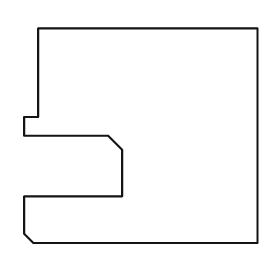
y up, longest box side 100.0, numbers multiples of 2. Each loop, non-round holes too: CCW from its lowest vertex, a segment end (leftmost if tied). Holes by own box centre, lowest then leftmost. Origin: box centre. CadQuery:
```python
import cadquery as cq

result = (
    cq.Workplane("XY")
    .moveTo(-46.0, -46.0)
    .lineTo(50.0, -46.0)
    .lineTo(50.0, 46.0)
    .lineTo(-44.0, 46.0)
    .lineTo(-44.0, 8.0)
    .lineTo(-50.0, 8.0)
    .lineTo(-50.0, 0.0)
    .lineTo(-14.0, 0.0)
    .lineTo(-8.0, -6.0)
    .lineTo(-8.0, -26.0)
    .lineTo(-50.0, -26.0)
    .lineTo(-50.0, -42.0)
    .close()
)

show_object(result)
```